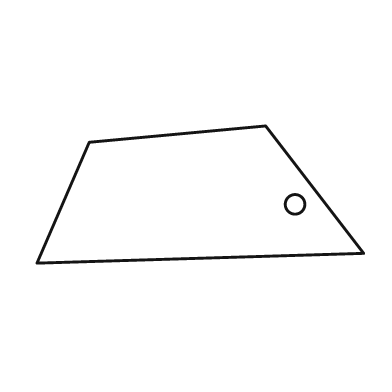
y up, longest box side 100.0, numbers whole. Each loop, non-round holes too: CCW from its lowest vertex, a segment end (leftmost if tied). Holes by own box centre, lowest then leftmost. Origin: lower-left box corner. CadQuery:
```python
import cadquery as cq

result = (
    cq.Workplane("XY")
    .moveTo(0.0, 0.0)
    .lineTo(100.0, 3.0)
    .lineTo(70.0, 42.0)
    .lineTo(16.0, 37.0)
    .close()
    .moveTo(79.0, 18.0)
    .circle(3.0)
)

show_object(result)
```